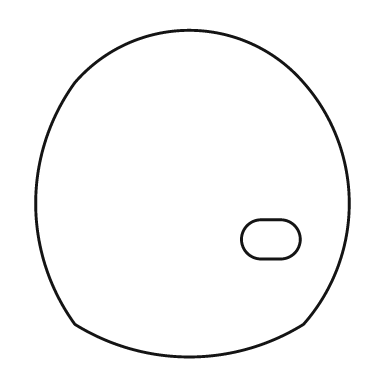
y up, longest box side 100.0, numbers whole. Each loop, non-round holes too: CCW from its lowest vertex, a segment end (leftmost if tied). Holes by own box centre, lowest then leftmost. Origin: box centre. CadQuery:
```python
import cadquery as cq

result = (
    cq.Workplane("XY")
    .moveTo(-36.0, -40.0)
    .threePointArc((-1.0, -50.0), (34.0, -40.0))
    .threePointArc((48.0, -3.0), (34.0, 34.0))
    .threePointArc((-1.0, 50.0), (-36.0, 34.0))
    .threePointArc((-48.0, -3.0), (-36.0, -40.0))
    .close()
    .moveTo(21.0, -20.0)
    .lineTo(27.0, -20.0)
    .threePointArc((33.0, -14.0), (27.0, -8.0))
    .lineTo(21.0, -8.0)
    .threePointArc((15.0, -14.0), (21.0, -20.0))
    .close()
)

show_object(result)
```